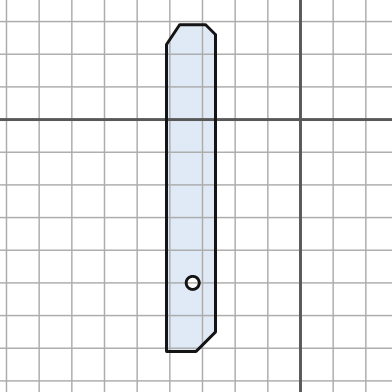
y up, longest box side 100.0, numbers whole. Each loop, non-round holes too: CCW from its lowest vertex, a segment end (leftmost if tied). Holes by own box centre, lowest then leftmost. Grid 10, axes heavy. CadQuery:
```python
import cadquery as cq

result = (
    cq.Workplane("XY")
    .moveTo(-41.0, -71.0)
    .lineTo(-32.0, -71.0)
    .lineTo(-26.0, -65.0)
    .lineTo(-26.0, 26.0)
    .lineTo(-29.0, 29.0)
    .lineTo(-37.0, 29.0)
    .lineTo(-41.0, 23.0)
    .close()
    .moveTo(-33.0, -50.0)
    .circle(2.0)
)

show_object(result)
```